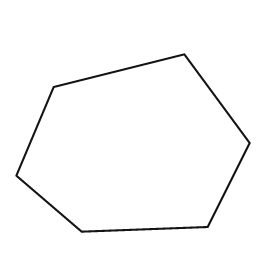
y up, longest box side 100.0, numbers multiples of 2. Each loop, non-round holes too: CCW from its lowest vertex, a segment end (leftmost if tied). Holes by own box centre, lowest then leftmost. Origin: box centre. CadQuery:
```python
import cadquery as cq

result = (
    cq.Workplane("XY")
    .moveTo(-22.0, -38.0)
    .lineTo(32.0, -36.0)
    .lineTo(50.0, 0.0)
    .lineTo(22.0, 38.0)
    .lineTo(-34.0, 24.0)
    .lineTo(-50.0, -14.0)
    .close()
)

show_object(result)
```